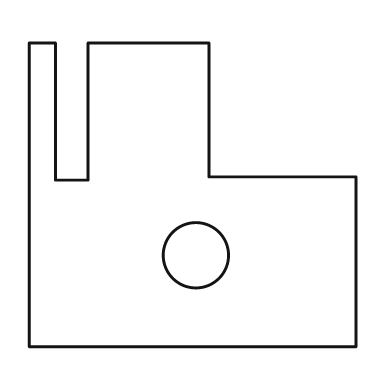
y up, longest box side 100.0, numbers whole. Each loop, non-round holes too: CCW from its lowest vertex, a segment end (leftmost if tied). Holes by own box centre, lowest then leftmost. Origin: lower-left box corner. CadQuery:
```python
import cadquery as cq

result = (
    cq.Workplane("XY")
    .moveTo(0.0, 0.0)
    .lineTo(100.0, 0.0)
    .lineTo(100.0, 52.0)
    .lineTo(55.0, 52.0)
    .lineTo(55.0, 93.0)
    .lineTo(18.0, 93.0)
    .lineTo(18.0, 51.0)
    .lineTo(8.0, 51.0)
    .lineTo(8.0, 93.0)
    .lineTo(0.0, 93.0)
    .close()
    .moveTo(51.0, 28.0)
    .circle(10.0)
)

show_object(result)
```